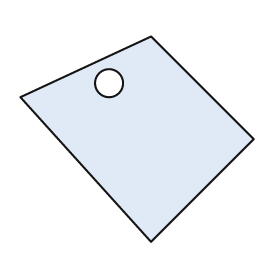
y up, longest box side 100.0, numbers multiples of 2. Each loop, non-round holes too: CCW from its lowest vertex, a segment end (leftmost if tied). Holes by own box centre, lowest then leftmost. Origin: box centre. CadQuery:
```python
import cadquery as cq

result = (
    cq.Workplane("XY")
    .moveTo(6.0, -44.0)
    .lineTo(50.0, 0.0)
    .lineTo(6.0, 44.0)
    .lineTo(-50.0, 18.0)
    .close()
    .moveTo(-12.0, 24.0)
    .circle(6.0)
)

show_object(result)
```